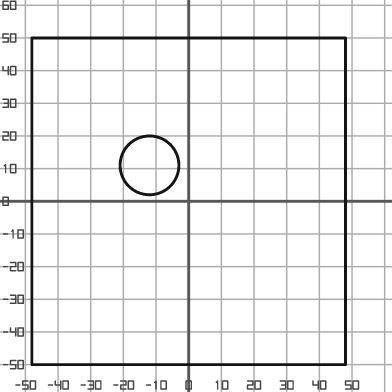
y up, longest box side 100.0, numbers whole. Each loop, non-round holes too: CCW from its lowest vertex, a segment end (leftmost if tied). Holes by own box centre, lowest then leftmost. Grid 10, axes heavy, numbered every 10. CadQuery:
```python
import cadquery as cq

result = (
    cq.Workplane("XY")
    .moveTo(-48.0, -50.0)
    .lineTo(48.0, -50.0)
    .lineTo(48.0, 50.0)
    .lineTo(-48.0, 50.0)
    .close()
    .moveTo(-12.0, 11.0)
    .circle(9.0)
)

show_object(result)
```